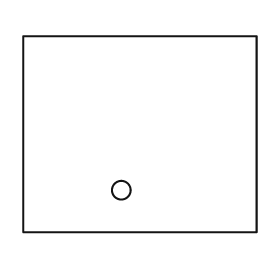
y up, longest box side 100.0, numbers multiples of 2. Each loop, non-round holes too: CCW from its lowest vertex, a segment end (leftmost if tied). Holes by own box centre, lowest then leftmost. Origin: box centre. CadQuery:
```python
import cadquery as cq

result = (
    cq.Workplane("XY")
    .moveTo(-50.0, -42.0)
    .lineTo(50.0, -42.0)
    .lineTo(50.0, 42.0)
    .lineTo(-50.0, 42.0)
    .close()
    .moveTo(-8.0, -24.0)
    .circle(4.0)
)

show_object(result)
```